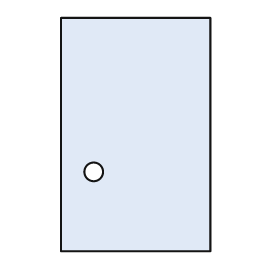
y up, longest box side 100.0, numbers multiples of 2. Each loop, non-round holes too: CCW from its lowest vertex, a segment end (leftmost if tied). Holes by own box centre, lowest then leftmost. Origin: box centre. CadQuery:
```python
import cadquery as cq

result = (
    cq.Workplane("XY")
    .moveTo(-32.0, -50.0)
    .lineTo(32.0, -50.0)
    .lineTo(32.0, 50.0)
    .lineTo(-32.0, 50.0)
    .close()
    .moveTo(-18.0, -16.0)
    .circle(4.0)
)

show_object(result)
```